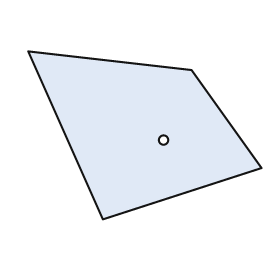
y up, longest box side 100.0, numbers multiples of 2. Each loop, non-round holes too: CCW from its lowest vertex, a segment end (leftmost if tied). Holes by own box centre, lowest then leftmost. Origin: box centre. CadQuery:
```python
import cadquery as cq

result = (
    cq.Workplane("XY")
    .moveTo(-18.0, -36.0)
    .lineTo(50.0, -14.0)
    .lineTo(20.0, 28.0)
    .lineTo(-50.0, 36.0)
    .close()
    .moveTo(8.0, -2.0)
    .circle(2.0)
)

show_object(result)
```